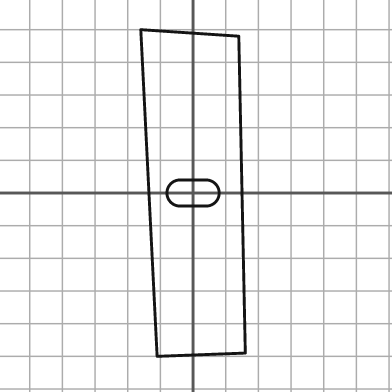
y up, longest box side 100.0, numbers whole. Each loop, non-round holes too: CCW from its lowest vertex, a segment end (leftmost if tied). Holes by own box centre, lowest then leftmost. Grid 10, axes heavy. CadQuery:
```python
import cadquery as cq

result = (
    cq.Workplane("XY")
    .moveTo(-11.0, -50.0)
    .lineTo(16.0, -49.0)
    .lineTo(14.0, 48.0)
    .lineTo(-16.0, 50.0)
    .close()
    .moveTo(-4.0, -4.0)
    .lineTo(4.0, -4.0)
    .threePointArc((8.0, 0.0), (4.0, 4.0))
    .lineTo(-4.0, 4.0)
    .threePointArc((-8.0, 0.0), (-4.0, -4.0))
    .close()
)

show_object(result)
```